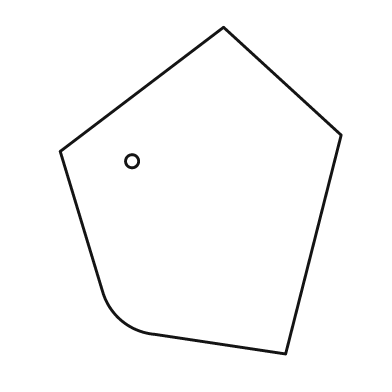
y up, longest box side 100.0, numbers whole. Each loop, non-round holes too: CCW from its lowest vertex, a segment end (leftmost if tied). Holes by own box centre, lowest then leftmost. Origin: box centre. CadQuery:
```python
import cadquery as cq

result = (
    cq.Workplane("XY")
    .moveTo(26.0, -50.0)
    .lineTo(43.0, 17.0)
    .lineTo(7.0, 50.0)
    .lineTo(-43.0, 12.0)
    .lineTo(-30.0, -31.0)
    .threePointArc((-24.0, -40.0), (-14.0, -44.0))
    .close()
    .moveTo(-21.0, 9.0)
    .circle(2.0)
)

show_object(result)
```